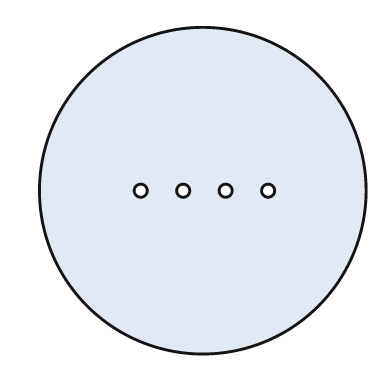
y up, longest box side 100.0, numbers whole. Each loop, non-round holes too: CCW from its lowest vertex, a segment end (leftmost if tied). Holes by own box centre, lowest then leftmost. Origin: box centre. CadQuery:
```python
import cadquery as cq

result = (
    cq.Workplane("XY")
    .moveTo(0.0, 0.0)
    .circle(50.0)
    .moveTo(-19.0, 0.0)
    .circle(2.0)
    .moveTo(-6.0, 0.0)
    .circle(2.0)
    .moveTo(7.0, 0.0)
    .circle(2.0)
    .moveTo(20.0, 0.0)
    .circle(2.0)
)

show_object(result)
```